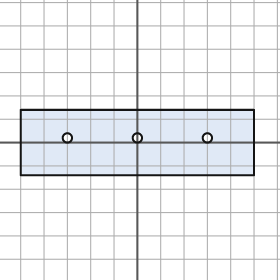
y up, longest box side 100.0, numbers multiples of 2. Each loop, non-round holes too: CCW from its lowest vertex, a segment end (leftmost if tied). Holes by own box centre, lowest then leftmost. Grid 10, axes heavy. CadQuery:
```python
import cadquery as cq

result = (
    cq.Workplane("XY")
    .moveTo(-50.0, -14.0)
    .lineTo(50.0, -14.0)
    .lineTo(50.0, 14.0)
    .lineTo(-50.0, 14.0)
    .close()
    .moveTo(-30.0, 2.0)
    .circle(2.0)
    .moveTo(0.0, 2.0)
    .circle(2.0)
    .moveTo(30.0, 2.0)
    .circle(2.0)
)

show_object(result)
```